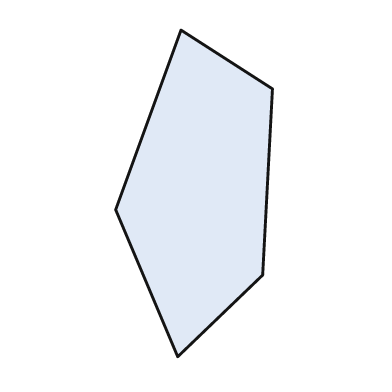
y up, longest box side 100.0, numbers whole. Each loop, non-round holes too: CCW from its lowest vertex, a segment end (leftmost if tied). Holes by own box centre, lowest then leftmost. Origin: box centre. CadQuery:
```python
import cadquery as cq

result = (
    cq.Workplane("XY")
    .moveTo(-5.0, -50.0)
    .lineTo(21.0, -25.0)
    .lineTo(24.0, 32.0)
    .lineTo(-4.0, 50.0)
    .lineTo(-24.0, -5.0)
    .close()
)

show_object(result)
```